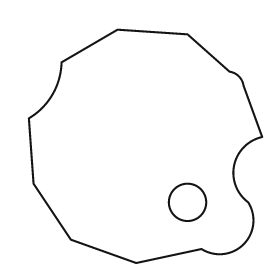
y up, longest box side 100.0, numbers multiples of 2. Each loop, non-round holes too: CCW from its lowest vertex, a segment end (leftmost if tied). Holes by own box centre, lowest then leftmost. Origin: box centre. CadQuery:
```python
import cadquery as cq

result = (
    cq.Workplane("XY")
    .moveTo(-4.0, -50.0)
    .lineTo(24.0, -44.0)
    .threePointArc((42.0, -42.0), (44.0, -24.0))
    .threePointArc((38.0, -8.0), (50.0, 4.0))
    .lineTo(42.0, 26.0)
    .threePointArc((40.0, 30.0), (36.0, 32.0))
    .lineTo(18.0, 48.0)
    .lineTo(-12.0, 50.0)
    .lineTo(-36.0, 36.0)
    .threePointArc((-40.0, 22.0), (-50.0, 12.0))
    .lineTo(-48.0, -16.0)
    .lineTo(-32.0, -40.0)
    .close()
    .moveTo(18.0, -24.0)
    .circle(8.0)
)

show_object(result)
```